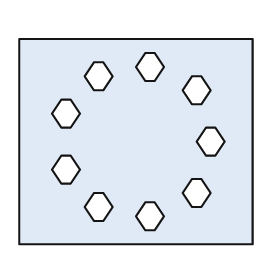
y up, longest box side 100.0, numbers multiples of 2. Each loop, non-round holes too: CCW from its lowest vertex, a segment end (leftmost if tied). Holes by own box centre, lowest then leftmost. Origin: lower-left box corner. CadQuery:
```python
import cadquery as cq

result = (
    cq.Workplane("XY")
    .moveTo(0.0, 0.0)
    .lineTo(100.0, 0.0)
    .lineTo(100.0, 88.0)
    .lineTo(0.0, 88.0)
    .close()
    .moveTo(54.0, 6.0)
    .lineTo(58.0, 6.0)
    .lineTo(62.0, 12.0)
    .lineTo(58.0, 18.0)
    .lineTo(54.0, 18.0)
    .lineTo(50.0, 12.0)
    .close()
    .moveTo(32.0, 10.0)
    .lineTo(36.0, 10.0)
    .lineTo(40.0, 16.0)
    .lineTo(36.0, 22.0)
    .lineTo(32.0, 22.0)
    .lineTo(28.0, 16.0)
    .close()
    .moveTo(74.0, 16.0)
    .lineTo(78.0, 16.0)
    .lineTo(82.0, 22.0)
    .lineTo(78.0, 28.0)
    .lineTo(74.0, 28.0)
    .lineTo(70.0, 22.0)
    .close()
    .moveTo(18.0, 26.0)
    .lineTo(22.0, 26.0)
    .lineTo(26.0, 32.0)
    .lineTo(22.0, 38.0)
    .lineTo(18.0, 38.0)
    .lineTo(14.0, 32.0)
    .close()
    .moveTo(80.0, 38.0)
    .lineTo(84.0, 38.0)
    .lineTo(88.0, 44.0)
    .lineTo(84.0, 50.0)
    .lineTo(80.0, 50.0)
    .lineTo(76.0, 44.0)
    .close()
    .moveTo(18.0, 50.0)
    .lineTo(22.0, 50.0)
    .lineTo(26.0, 56.0)
    .lineTo(22.0, 62.0)
    .lineTo(18.0, 62.0)
    .lineTo(14.0, 56.0)
    .close()
    .moveTo(74.0, 60.0)
    .lineTo(78.0, 60.0)
    .lineTo(82.0, 66.0)
    .lineTo(78.0, 72.0)
    .lineTo(74.0, 72.0)
    .lineTo(70.0, 66.0)
    .close()
    .moveTo(32.0, 66.0)
    .lineTo(36.0, 66.0)
    .lineTo(40.0, 72.0)
    .lineTo(36.0, 78.0)
    .lineTo(32.0, 78.0)
    .lineTo(28.0, 72.0)
    .close()
    .moveTo(54.0, 70.0)
    .lineTo(58.0, 70.0)
    .lineTo(62.0, 76.0)
    .lineTo(58.0, 82.0)
    .lineTo(54.0, 82.0)
    .lineTo(50.0, 76.0)
    .close()
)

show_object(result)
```